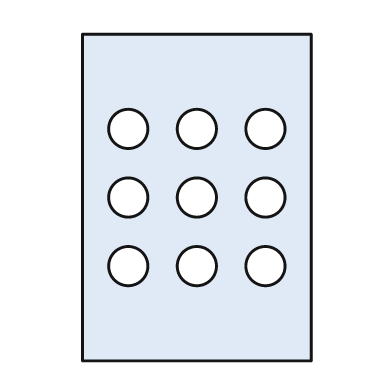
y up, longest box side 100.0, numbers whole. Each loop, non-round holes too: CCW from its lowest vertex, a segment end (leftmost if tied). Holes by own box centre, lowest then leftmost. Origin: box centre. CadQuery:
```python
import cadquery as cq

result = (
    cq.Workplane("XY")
    .moveTo(-35.0, -50.0)
    .lineTo(35.0, -50.0)
    .lineTo(35.0, 50.0)
    .lineTo(-35.0, 50.0)
    .close()
    .moveTo(-21.0, -21.0)
    .circle(6.0)
    .moveTo(0.0, -21.0)
    .circle(6.0)
    .moveTo(21.0, -21.0)
    .circle(6.0)
    .moveTo(-21.0, 0.0)
    .circle(6.0)
    .moveTo(0.0, 0.0)
    .circle(6.0)
    .moveTo(21.0, 0.0)
    .circle(6.0)
    .moveTo(-21.0, 21.0)
    .circle(6.0)
    .moveTo(0.0, 21.0)
    .circle(6.0)
    .moveTo(21.0, 21.0)
    .circle(6.0)
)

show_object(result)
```